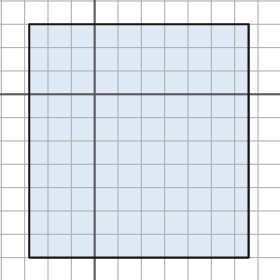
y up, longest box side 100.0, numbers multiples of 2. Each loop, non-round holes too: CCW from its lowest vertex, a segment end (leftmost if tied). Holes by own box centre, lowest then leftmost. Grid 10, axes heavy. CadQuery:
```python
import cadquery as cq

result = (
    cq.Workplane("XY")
    .moveTo(-28.0, -70.0)
    .lineTo(66.0, -70.0)
    .lineTo(66.0, 30.0)
    .lineTo(-28.0, 30.0)
    .close()
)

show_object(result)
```